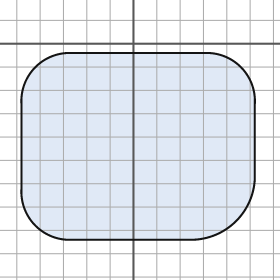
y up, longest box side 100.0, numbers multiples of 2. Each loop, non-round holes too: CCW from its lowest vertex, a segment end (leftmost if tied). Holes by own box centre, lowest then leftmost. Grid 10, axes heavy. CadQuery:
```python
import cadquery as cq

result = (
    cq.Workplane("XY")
    .moveTo(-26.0, -84.0)
    .lineTo(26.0, -84.0)
    .threePointArc((44.0, -76.0), (52.0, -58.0))
    .lineTo(52.0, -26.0)
    .threePointArc((46.0, -10.0), (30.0, -4.0))
    .lineTo(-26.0, -4.0)
    .threePointArc((-42.0, -10.0), (-48.0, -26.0))
    .lineTo(-48.0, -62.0)
    .threePointArc((-42.0, -78.0), (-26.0, -84.0))
    .close()
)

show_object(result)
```